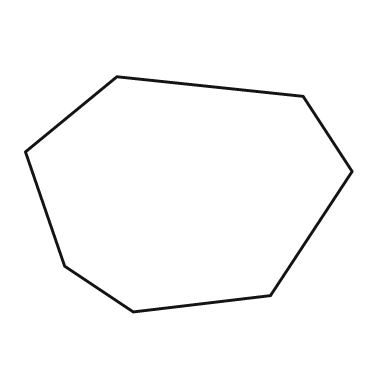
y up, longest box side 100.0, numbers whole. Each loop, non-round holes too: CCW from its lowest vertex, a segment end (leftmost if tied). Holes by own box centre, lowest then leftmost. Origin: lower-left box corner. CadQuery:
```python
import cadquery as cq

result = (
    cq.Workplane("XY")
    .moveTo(33.0, 0.0)
    .lineTo(75.0, 5.0)
    .lineTo(100.0, 43.0)
    .lineTo(85.0, 66.0)
    .lineTo(28.0, 72.0)
    .lineTo(0.0, 49.0)
    .lineTo(12.0, 14.0)
    .close()
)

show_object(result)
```